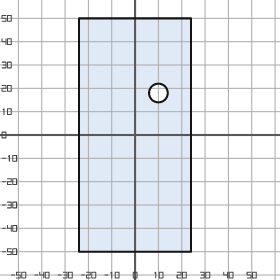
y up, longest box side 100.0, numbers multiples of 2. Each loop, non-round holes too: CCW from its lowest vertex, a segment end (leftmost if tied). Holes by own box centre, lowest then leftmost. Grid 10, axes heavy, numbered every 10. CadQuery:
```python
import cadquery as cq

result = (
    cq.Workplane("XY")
    .moveTo(-24.0, -50.0)
    .lineTo(24.0, -50.0)
    .lineTo(24.0, 50.0)
    .lineTo(-24.0, 50.0)
    .close()
    .moveTo(10.0, 18.0)
    .circle(4.0)
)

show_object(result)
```